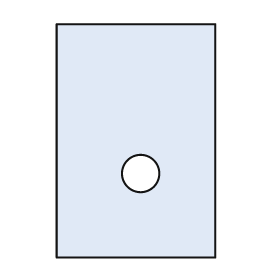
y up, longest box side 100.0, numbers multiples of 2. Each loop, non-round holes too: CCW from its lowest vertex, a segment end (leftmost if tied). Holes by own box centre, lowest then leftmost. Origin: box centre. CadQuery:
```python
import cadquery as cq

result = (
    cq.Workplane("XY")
    .moveTo(-34.0, -50.0)
    .lineTo(34.0, -50.0)
    .lineTo(34.0, 50.0)
    .lineTo(-34.0, 50.0)
    .close()
    .moveTo(2.0, -14.0)
    .circle(8.0)
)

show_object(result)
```